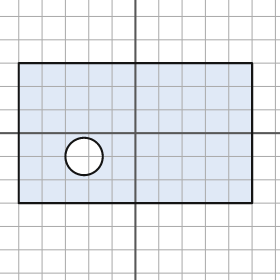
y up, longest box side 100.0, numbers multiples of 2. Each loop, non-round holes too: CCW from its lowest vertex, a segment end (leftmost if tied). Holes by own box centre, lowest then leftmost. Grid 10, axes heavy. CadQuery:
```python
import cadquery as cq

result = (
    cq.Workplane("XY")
    .moveTo(-50.0, -30.0)
    .lineTo(50.0, -30.0)
    .lineTo(50.0, 30.0)
    .lineTo(-50.0, 30.0)
    .close()
    .moveTo(-22.0, -10.0)
    .circle(8.0)
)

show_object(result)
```